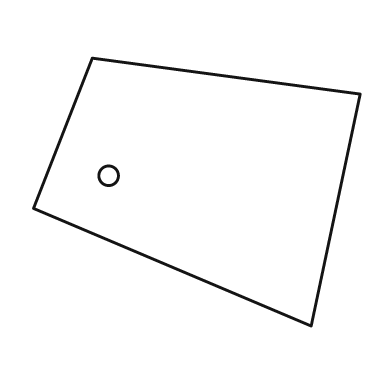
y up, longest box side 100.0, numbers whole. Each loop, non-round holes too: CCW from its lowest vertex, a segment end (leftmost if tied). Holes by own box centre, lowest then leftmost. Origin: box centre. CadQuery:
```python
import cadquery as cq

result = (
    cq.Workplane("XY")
    .moveTo(35.0, -41.0)
    .lineTo(50.0, 30.0)
    .lineTo(-32.0, 41.0)
    .lineTo(-50.0, -5.0)
    .close()
    .moveTo(-27.0, 5.0)
    .circle(3.0)
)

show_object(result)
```